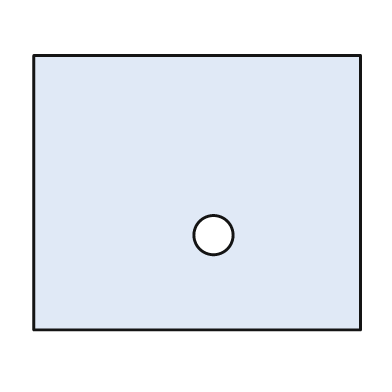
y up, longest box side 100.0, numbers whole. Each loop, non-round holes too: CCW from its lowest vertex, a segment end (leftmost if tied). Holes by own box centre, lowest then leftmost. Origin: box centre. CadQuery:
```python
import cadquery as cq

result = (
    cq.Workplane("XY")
    .moveTo(-50.0, -42.0)
    .lineTo(50.0, -42.0)
    .lineTo(50.0, 42.0)
    .lineTo(-50.0, 42.0)
    .close()
    .moveTo(5.0, -13.0)
    .circle(6.0)
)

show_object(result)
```